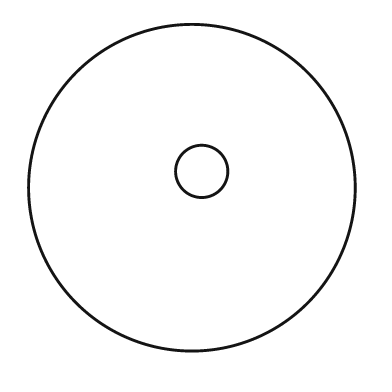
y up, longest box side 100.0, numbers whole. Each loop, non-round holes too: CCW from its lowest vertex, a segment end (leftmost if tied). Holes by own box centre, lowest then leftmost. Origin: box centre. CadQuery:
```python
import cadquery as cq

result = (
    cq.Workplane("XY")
    .moveTo(0.0, 0.0)
    .circle(50.0)
    .moveTo(3.0, 5.0)
    .circle(8.0)
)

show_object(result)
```